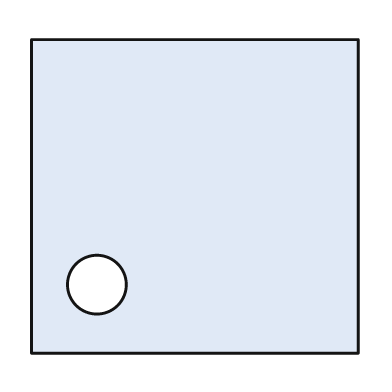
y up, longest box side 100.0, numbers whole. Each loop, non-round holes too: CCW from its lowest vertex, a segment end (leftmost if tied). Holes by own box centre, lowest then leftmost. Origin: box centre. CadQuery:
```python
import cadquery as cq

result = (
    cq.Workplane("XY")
    .moveTo(-50.0, -48.0)
    .lineTo(50.0, -48.0)
    .lineTo(50.0, 48.0)
    .lineTo(-50.0, 48.0)
    .close()
    .moveTo(-30.0, -27.0)
    .circle(9.0)
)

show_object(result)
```